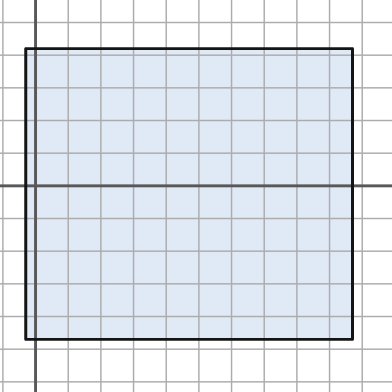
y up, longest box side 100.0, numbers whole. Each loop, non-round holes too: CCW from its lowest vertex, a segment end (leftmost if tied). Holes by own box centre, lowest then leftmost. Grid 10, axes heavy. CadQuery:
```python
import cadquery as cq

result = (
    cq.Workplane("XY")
    .moveTo(-3.0, -47.0)
    .lineTo(97.0, -47.0)
    .lineTo(97.0, 42.0)
    .lineTo(-3.0, 42.0)
    .close()
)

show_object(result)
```